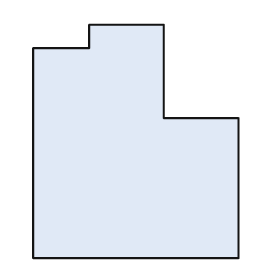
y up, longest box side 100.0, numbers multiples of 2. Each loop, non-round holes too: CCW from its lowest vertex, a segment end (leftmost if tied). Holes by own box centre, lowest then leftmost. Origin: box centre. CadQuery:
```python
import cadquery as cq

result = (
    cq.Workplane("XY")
    .moveTo(-44.0, -50.0)
    .lineTo(44.0, -50.0)
    .lineTo(44.0, 10.0)
    .lineTo(12.0, 10.0)
    .lineTo(12.0, 50.0)
    .lineTo(-20.0, 50.0)
    .lineTo(-20.0, 40.0)
    .lineTo(-44.0, 40.0)
    .close()
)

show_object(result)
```